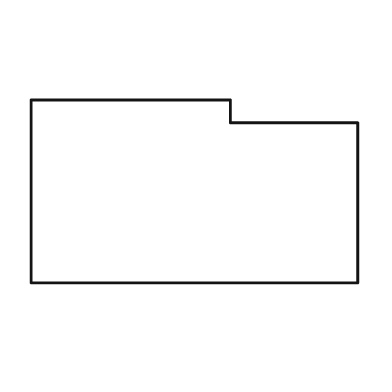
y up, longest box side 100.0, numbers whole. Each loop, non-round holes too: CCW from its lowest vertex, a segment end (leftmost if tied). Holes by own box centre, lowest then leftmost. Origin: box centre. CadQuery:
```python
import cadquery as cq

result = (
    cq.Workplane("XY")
    .moveTo(-50.0, -28.0)
    .lineTo(50.0, -28.0)
    .lineTo(50.0, 21.0)
    .lineTo(11.0, 21.0)
    .lineTo(11.0, 28.0)
    .lineTo(-50.0, 28.0)
    .close()
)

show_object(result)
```